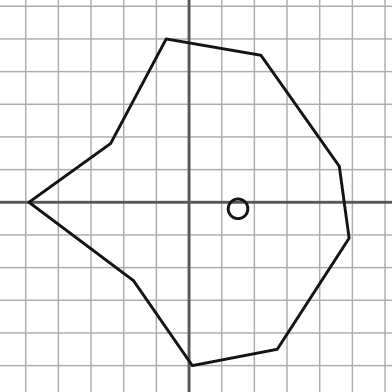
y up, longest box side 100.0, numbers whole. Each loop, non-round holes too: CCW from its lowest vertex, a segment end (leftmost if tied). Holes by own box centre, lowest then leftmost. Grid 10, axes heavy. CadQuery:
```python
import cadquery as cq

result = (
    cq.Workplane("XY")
    .moveTo(1.0, -50.0)
    .lineTo(27.0, -45.0)
    .lineTo(49.0, -11.0)
    .lineTo(46.0, 11.0)
    .lineTo(22.0, 45.0)
    .lineTo(-7.0, 50.0)
    .lineTo(-24.0, 18.0)
    .lineTo(-49.0, 0.0)
    .lineTo(-17.0, -24.0)
    .close()
    .moveTo(15.0, -2.0)
    .circle(3.0)
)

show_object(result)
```